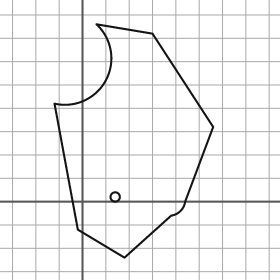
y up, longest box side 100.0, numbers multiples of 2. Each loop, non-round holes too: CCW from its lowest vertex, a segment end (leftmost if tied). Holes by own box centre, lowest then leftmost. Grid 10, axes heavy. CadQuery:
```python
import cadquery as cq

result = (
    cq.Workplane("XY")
    .moveTo(18.0, -24.0)
    .lineTo(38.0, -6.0)
    .threePointArc((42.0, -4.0), (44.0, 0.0))
    .lineTo(56.0, 32.0)
    .lineTo(30.0, 72.0)
    .lineTo(6.0, 76.0)
    .threePointArc((10.0, 52.0), (-12.0, 42.0))
    .lineTo(-2.0, -12.0)
    .close()
    .moveTo(14.0, 2.0)
    .circle(2.0)
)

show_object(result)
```